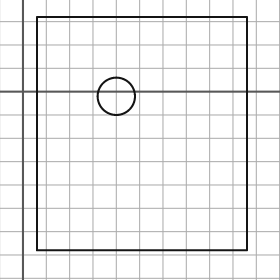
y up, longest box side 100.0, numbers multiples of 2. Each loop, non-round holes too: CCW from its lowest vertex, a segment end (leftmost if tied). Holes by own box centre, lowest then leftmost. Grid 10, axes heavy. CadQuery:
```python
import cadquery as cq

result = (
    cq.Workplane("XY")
    .moveTo(6.0, -68.0)
    .lineTo(96.0, -68.0)
    .lineTo(96.0, 32.0)
    .lineTo(6.0, 32.0)
    .close()
    .moveTo(40.0, -2.0)
    .circle(8.0)
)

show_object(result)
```